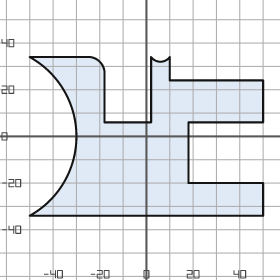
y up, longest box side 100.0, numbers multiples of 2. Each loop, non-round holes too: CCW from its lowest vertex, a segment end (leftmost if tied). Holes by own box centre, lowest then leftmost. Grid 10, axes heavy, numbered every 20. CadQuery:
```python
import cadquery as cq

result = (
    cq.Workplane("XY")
    .moveTo(-50.0, -34.0)
    .lineTo(50.0, -34.0)
    .lineTo(50.0, -20.0)
    .lineTo(18.0, -20.0)
    .lineTo(18.0, 6.0)
    .lineTo(50.0, 6.0)
    .lineTo(50.0, 24.0)
    .lineTo(10.0, 24.0)
    .lineTo(10.0, 34.0)
    .threePointArc((6.0, 32.0), (2.0, 34.0))
    .lineTo(2.0, 6.0)
    .lineTo(-18.0, 6.0)
    .lineTo(-18.0, 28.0)
    .threePointArc((-20.0, 32.0), (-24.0, 34.0))
    .lineTo(-50.0, 34.0)
    .threePointArc((-30.0, 0.0), (-50.0, -34.0))
    .close()
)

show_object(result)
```